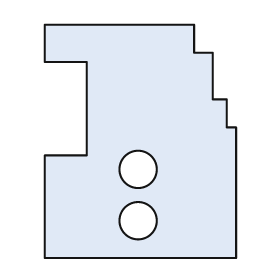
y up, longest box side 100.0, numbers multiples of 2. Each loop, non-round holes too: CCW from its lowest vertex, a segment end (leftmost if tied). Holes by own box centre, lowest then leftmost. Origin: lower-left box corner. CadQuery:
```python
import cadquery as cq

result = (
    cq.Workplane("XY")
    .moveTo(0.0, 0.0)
    .lineTo(82.0, 0.0)
    .lineTo(82.0, 56.0)
    .lineTo(78.0, 56.0)
    .lineTo(78.0, 68.0)
    .lineTo(72.0, 68.0)
    .lineTo(72.0, 88.0)
    .lineTo(64.0, 88.0)
    .lineTo(64.0, 100.0)
    .lineTo(0.0, 100.0)
    .lineTo(0.0, 84.0)
    .lineTo(18.0, 84.0)
    .lineTo(18.0, 44.0)
    .lineTo(0.0, 44.0)
    .close()
    .moveTo(40.0, 16.0)
    .circle(8.0)
    .moveTo(40.0, 38.0)
    .circle(8.0)
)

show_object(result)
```